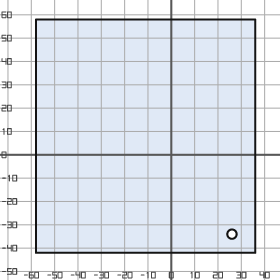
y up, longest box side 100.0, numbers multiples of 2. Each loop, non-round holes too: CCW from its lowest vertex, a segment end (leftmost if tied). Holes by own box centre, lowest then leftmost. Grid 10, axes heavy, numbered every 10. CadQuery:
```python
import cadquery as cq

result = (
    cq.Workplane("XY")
    .moveTo(-58.0, -42.0)
    .lineTo(36.0, -42.0)
    .lineTo(36.0, 58.0)
    .lineTo(-58.0, 58.0)
    .close()
    .moveTo(26.0, -34.0)
    .circle(2.0)
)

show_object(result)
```